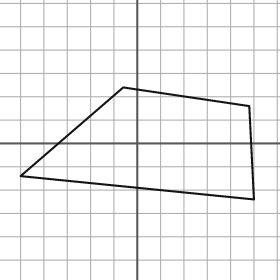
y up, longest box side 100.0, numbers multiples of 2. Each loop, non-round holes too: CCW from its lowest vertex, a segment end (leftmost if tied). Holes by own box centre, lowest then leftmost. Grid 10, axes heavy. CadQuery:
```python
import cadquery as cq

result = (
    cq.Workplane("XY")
    .moveTo(50.0, -24.0)
    .lineTo(48.0, 16.0)
    .lineTo(-6.0, 24.0)
    .lineTo(-50.0, -14.0)
    .close()
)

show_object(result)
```